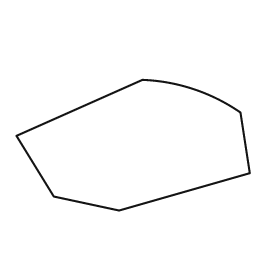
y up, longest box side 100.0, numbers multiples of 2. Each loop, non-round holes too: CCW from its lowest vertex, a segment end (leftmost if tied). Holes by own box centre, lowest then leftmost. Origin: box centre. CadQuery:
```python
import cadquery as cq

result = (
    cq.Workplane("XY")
    .moveTo(-6.0, -28.0)
    .lineTo(50.0, -12.0)
    .lineTo(46.0, 14.0)
    .threePointArc((26.0, 24.0), (4.0, 28.0))
    .lineTo(-50.0, 4.0)
    .lineTo(-34.0, -22.0)
    .close()
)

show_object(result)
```